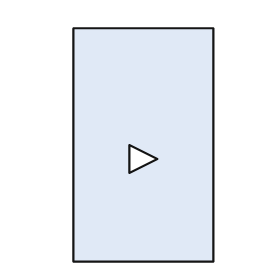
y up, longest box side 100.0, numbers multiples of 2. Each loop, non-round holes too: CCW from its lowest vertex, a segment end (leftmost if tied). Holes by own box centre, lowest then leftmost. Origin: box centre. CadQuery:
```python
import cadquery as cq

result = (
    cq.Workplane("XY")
    .moveTo(-30.0, -50.0)
    .lineTo(30.0, -50.0)
    .lineTo(30.0, 50.0)
    .lineTo(-30.0, 50.0)
    .close()
    .moveTo(-6.0, -12.0)
    .lineTo(6.0, -6.0)
    .lineTo(-6.0, 0.0)
    .close()
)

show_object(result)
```